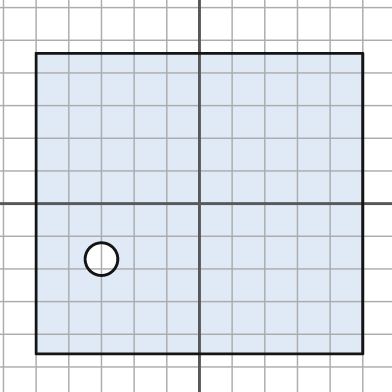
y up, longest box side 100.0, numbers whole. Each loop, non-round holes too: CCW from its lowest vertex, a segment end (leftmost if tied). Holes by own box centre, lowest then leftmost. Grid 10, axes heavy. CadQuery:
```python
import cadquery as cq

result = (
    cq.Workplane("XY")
    .moveTo(-50.0, -46.0)
    .lineTo(50.0, -46.0)
    .lineTo(50.0, 46.0)
    .lineTo(-50.0, 46.0)
    .close()
    .moveTo(-30.0, -17.0)
    .circle(5.0)
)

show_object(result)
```